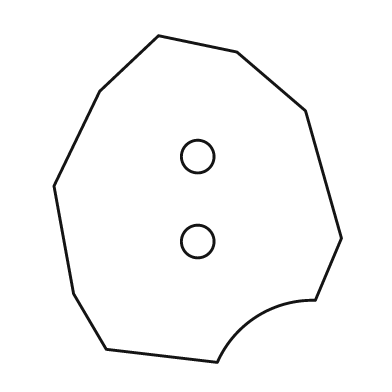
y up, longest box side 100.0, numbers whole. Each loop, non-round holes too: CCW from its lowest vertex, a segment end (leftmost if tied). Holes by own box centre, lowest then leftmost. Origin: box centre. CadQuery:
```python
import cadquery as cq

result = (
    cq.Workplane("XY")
    .moveTo(6.0, -50.0)
    .threePointArc((18.0, -36.0), (36.0, -31.0))
    .lineTo(44.0, -12.0)
    .lineTo(33.0, 27.0)
    .lineTo(12.0, 45.0)
    .lineTo(-12.0, 50.0)
    .lineTo(-30.0, 33.0)
    .lineTo(-44.0, 4.0)
    .lineTo(-38.0, -29.0)
    .lineTo(-28.0, -46.0)
    .close()
    .moveTo(0.0, -13.0)
    .circle(5.0)
    .moveTo(0.0, 13.0)
    .circle(5.0)
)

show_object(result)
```